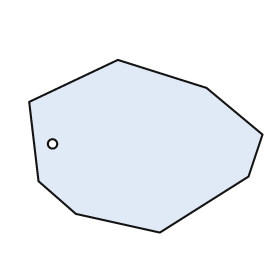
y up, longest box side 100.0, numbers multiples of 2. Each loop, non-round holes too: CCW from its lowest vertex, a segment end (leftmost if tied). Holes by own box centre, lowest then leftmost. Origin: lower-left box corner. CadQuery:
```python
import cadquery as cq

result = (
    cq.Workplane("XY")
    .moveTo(56.0, 0.0)
    .lineTo(94.0, 24.0)
    .lineTo(100.0, 42.0)
    .lineTo(76.0, 62.0)
    .lineTo(38.0, 74.0)
    .lineTo(0.0, 56.0)
    .lineTo(4.0, 22.0)
    .lineTo(20.0, 8.0)
    .close()
    .moveTo(10.0, 38.0)
    .circle(2.0)
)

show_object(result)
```